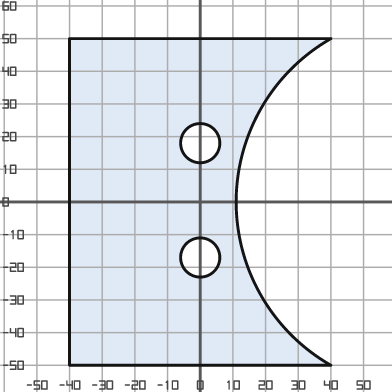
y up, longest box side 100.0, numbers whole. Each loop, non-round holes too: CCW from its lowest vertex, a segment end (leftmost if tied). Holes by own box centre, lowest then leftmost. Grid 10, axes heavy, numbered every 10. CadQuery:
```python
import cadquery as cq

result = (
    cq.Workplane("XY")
    .moveTo(-40.0, -50.0)
    .lineTo(40.0, -50.0)
    .threePointArc((11.0, 0.0), (40.0, 50.0))
    .lineTo(-40.0, 50.0)
    .close()
    .moveTo(0.0, -17.0)
    .circle(6.0)
    .moveTo(0.0, 18.0)
    .circle(6.0)
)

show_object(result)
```